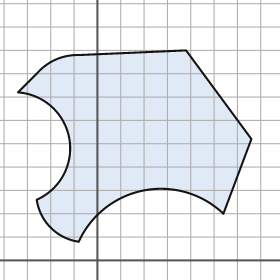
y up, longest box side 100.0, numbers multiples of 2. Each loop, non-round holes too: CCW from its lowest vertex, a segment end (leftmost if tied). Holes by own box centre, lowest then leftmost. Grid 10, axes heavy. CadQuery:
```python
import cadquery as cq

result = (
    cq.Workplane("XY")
    .moveTo(-8.0, 8.0)
    .threePointArc((20.0, 30.0), (54.0, 20.0))
    .lineTo(66.0, 52.0)
    .lineTo(38.0, 90.0)
    .lineTo(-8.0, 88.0)
    .threePointArc((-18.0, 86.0), (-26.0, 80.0))
    .lineTo(-34.0, 72.0)
    .threePointArc((-12.0, 52.0), (-26.0, 26.0))
    .threePointArc((-20.0, 14.0), (-8.0, 8.0))
    .close()
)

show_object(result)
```